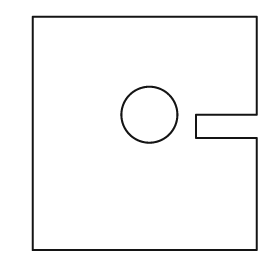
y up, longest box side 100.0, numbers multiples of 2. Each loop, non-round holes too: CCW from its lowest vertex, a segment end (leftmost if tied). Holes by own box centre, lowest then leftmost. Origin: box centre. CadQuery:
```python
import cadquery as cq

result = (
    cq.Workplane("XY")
    .moveTo(-48.0, -50.0)
    .lineTo(48.0, -50.0)
    .lineTo(48.0, -2.0)
    .lineTo(22.0, -2.0)
    .lineTo(22.0, 8.0)
    .lineTo(48.0, 8.0)
    .lineTo(48.0, 50.0)
    .lineTo(-48.0, 50.0)
    .close()
    .moveTo(2.0, 8.0)
    .circle(12.0)
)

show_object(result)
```